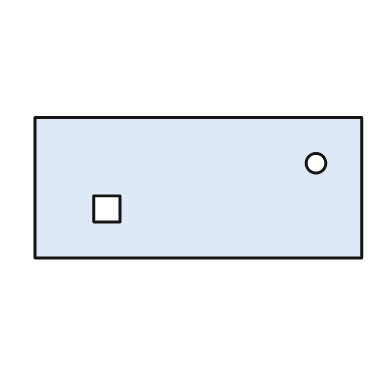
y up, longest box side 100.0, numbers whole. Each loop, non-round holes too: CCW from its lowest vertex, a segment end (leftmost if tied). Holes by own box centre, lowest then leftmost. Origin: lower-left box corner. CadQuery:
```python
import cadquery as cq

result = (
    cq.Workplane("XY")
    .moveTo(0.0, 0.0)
    .lineTo(100.0, 0.0)
    .lineTo(100.0, 43.0)
    .lineTo(0.0, 43.0)
    .close()
    .moveTo(18.0, 11.0)
    .lineTo(26.0, 11.0)
    .lineTo(26.0, 19.0)
    .lineTo(18.0, 19.0)
    .close()
    .moveTo(86.0, 29.0)
    .circle(3.0)
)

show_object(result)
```